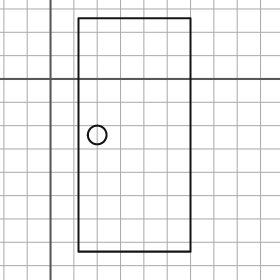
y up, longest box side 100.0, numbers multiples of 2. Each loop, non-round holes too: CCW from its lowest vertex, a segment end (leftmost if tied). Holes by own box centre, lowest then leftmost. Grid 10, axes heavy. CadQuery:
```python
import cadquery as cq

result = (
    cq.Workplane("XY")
    .moveTo(12.0, -74.0)
    .lineTo(60.0, -74.0)
    .lineTo(60.0, 26.0)
    .lineTo(12.0, 26.0)
    .close()
    .moveTo(20.0, -24.0)
    .circle(4.0)
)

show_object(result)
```